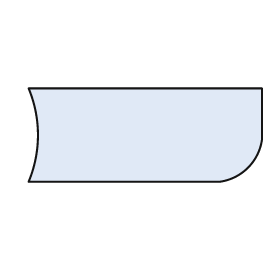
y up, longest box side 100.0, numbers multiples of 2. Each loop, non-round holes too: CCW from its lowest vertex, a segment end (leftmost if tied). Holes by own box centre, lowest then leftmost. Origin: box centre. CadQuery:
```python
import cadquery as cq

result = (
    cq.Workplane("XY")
    .moveTo(-50.0, -20.0)
    .lineTo(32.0, -20.0)
    .threePointArc((44.0, -14.0), (50.0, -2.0))
    .lineTo(50.0, 20.0)
    .lineTo(-50.0, 20.0)
    .threePointArc((-46.0, 0.0), (-50.0, -20.0))
    .close()
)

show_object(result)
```